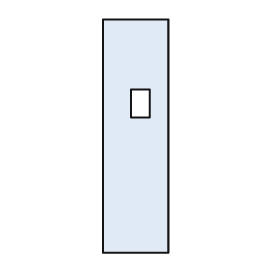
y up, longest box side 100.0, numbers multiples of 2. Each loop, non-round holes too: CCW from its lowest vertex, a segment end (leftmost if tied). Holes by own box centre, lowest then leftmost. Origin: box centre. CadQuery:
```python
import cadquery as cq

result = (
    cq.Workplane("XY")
    .moveTo(-14.0, -50.0)
    .lineTo(14.0, -50.0)
    .lineTo(14.0, 50.0)
    .lineTo(-14.0, 50.0)
    .close()
    .moveTo(-2.0, 8.0)
    .lineTo(6.0, 8.0)
    .lineTo(6.0, 20.0)
    .lineTo(-2.0, 20.0)
    .close()
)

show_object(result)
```